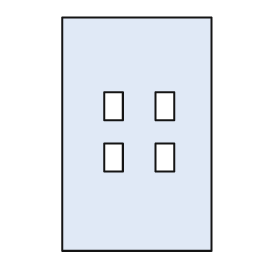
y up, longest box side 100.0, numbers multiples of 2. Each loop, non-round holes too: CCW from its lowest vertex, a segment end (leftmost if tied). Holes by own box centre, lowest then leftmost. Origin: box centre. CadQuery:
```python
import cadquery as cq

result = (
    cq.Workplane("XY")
    .moveTo(-32.0, -50.0)
    .lineTo(32.0, -50.0)
    .lineTo(32.0, 50.0)
    .lineTo(-32.0, 50.0)
    .close()
    .moveTo(-14.0, -16.0)
    .lineTo(-6.0, -16.0)
    .lineTo(-6.0, -4.0)
    .lineTo(-14.0, -4.0)
    .close()
    .moveTo(8.0, -16.0)
    .lineTo(16.0, -16.0)
    .lineTo(16.0, -4.0)
    .lineTo(8.0, -4.0)
    .close()
    .moveTo(-14.0, 6.0)
    .lineTo(-6.0, 6.0)
    .lineTo(-6.0, 18.0)
    .lineTo(-14.0, 18.0)
    .close()
    .moveTo(8.0, 6.0)
    .lineTo(16.0, 6.0)
    .lineTo(16.0, 18.0)
    .lineTo(8.0, 18.0)
    .close()
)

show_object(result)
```